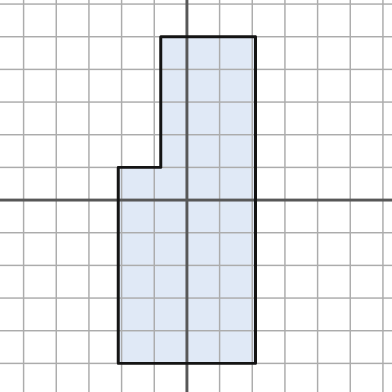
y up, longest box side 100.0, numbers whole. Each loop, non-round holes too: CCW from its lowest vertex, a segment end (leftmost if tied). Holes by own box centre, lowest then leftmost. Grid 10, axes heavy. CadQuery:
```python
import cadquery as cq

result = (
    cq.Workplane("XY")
    .moveTo(-21.0, -50.0)
    .lineTo(21.0, -50.0)
    .lineTo(21.0, 50.0)
    .lineTo(-8.0, 50.0)
    .lineTo(-8.0, 10.0)
    .lineTo(-21.0, 10.0)
    .close()
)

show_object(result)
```